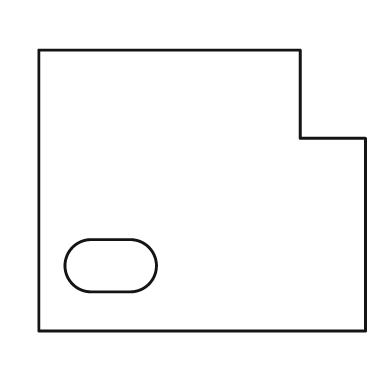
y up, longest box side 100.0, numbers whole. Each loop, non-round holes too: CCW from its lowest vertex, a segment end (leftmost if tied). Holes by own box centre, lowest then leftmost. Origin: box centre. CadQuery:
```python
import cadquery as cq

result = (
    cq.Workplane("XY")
    .moveTo(-50.0, -43.0)
    .lineTo(50.0, -43.0)
    .lineTo(50.0, 16.0)
    .lineTo(30.0, 16.0)
    .lineTo(30.0, 43.0)
    .lineTo(-50.0, 43.0)
    .close()
    .moveTo(-34.0, -31.0)
    .lineTo(-22.0, -31.0)
    .threePointArc((-14.0, -23.0), (-22.0, -15.0))
    .lineTo(-34.0, -15.0)
    .threePointArc((-42.0, -23.0), (-34.0, -31.0))
    .close()
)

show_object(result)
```